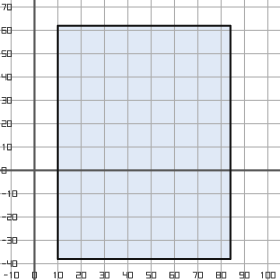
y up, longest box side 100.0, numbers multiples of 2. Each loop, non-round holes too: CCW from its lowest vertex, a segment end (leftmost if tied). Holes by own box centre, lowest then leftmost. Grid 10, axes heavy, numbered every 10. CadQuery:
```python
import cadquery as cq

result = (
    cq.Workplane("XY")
    .moveTo(10.0, -38.0)
    .lineTo(84.0, -38.0)
    .lineTo(84.0, 62.0)
    .lineTo(10.0, 62.0)
    .close()
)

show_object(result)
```